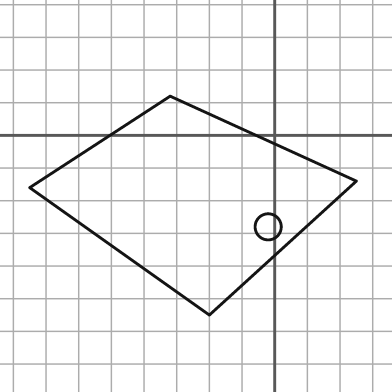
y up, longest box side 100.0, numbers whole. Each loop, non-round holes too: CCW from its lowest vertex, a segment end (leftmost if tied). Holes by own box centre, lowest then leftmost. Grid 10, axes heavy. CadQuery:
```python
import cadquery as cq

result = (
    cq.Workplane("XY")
    .moveTo(-20.0, -55.0)
    .lineTo(25.0, -14.0)
    .lineTo(-32.0, 12.0)
    .lineTo(-75.0, -16.0)
    .close()
    .moveTo(-2.0, -28.0)
    .circle(4.0)
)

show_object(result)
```